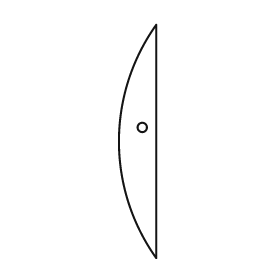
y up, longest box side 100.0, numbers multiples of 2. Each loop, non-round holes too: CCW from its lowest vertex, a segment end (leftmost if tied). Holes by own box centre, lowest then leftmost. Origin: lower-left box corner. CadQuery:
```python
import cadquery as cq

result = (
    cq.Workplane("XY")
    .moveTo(16.0, 0.0)
    .lineTo(16.0, 100.0)
    .threePointArc((0.0, 50.0), (16.0, 0.0))
    .close()
    .moveTo(10.0, 56.0)
    .circle(2.0)
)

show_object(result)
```